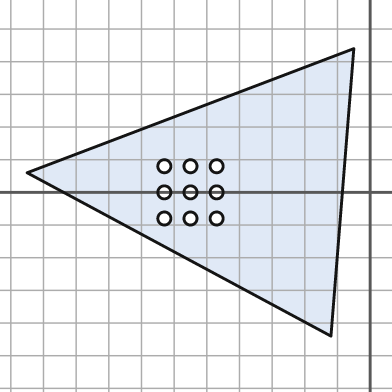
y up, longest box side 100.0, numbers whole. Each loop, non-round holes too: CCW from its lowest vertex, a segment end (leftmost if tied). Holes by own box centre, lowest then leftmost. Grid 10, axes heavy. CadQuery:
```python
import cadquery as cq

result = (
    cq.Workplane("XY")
    .moveTo(-12.0, -44.0)
    .lineTo(-5.0, 44.0)
    .lineTo(-105.0, 6.0)
    .close()
    .moveTo(-63.0, -8.0)
    .circle(2.0)
    .moveTo(-55.0, -8.0)
    .circle(2.0)
    .moveTo(-47.0, -8.0)
    .circle(2.0)
    .moveTo(-63.0, 0.0)
    .circle(2.0)
    .moveTo(-55.0, 0.0)
    .circle(2.0)
    .moveTo(-47.0, 0.0)
    .circle(2.0)
    .moveTo(-63.0, 8.0)
    .circle(2.0)
    .moveTo(-55.0, 8.0)
    .circle(2.0)
    .moveTo(-47.0, 8.0)
    .circle(2.0)
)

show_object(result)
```